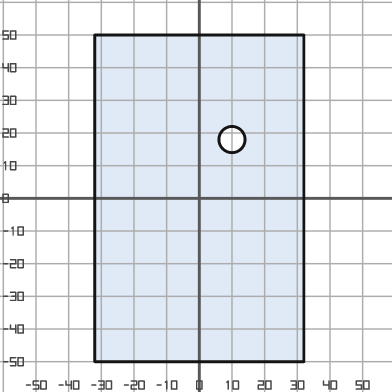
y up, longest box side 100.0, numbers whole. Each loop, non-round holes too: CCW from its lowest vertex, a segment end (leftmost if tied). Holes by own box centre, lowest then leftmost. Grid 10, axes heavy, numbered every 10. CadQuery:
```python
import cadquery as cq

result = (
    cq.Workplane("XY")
    .moveTo(-32.0, -50.0)
    .lineTo(32.0, -50.0)
    .lineTo(32.0, 50.0)
    .lineTo(-32.0, 50.0)
    .close()
    .moveTo(10.0, 18.0)
    .circle(4.0)
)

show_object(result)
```